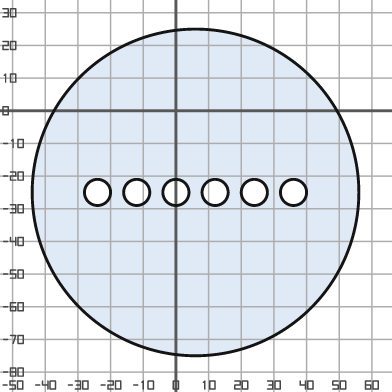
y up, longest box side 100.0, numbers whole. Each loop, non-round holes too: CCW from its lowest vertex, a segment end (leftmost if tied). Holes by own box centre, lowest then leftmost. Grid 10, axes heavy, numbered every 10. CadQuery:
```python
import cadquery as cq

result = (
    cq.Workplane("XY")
    .moveTo(6.0, -25.0)
    .circle(50.0)
    .moveTo(-24.0, -25.0)
    .circle(4.0)
    .moveTo(-12.0, -25.0)
    .circle(4.0)
    .moveTo(0.0, -25.0)
    .circle(4.0)
    .moveTo(12.0, -25.0)
    .circle(4.0)
    .moveTo(24.0, -25.0)
    .circle(4.0)
    .moveTo(36.0, -25.0)
    .circle(4.0)
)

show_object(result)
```